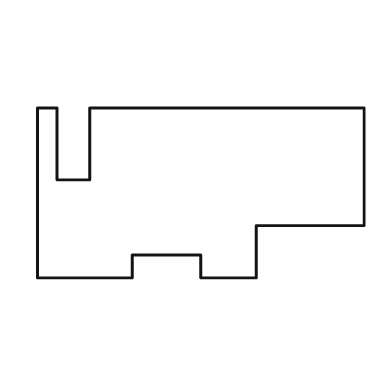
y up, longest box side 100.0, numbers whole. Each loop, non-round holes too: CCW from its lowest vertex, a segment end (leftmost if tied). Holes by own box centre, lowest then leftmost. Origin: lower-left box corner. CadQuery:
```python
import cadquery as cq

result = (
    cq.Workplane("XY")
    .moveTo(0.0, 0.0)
    .lineTo(29.0, 0.0)
    .lineTo(29.0, 7.0)
    .lineTo(50.0, 7.0)
    .lineTo(50.0, 0.0)
    .lineTo(67.0, 0.0)
    .lineTo(67.0, 16.0)
    .lineTo(100.0, 16.0)
    .lineTo(100.0, 52.0)
    .lineTo(16.0, 52.0)
    .lineTo(16.0, 30.0)
    .lineTo(6.0, 30.0)
    .lineTo(6.0, 52.0)
    .lineTo(0.0, 52.0)
    .close()
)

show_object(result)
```